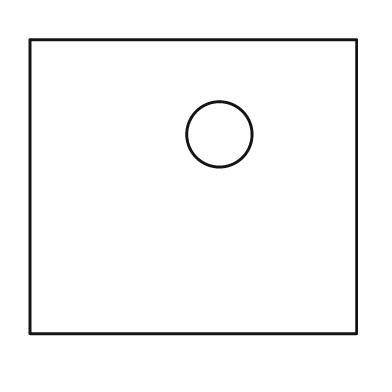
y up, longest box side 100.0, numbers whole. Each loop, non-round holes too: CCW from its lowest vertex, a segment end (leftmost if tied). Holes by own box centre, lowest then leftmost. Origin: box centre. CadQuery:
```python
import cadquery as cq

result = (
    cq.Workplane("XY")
    .moveTo(-50.0, -45.0)
    .lineTo(50.0, -45.0)
    .lineTo(50.0, 45.0)
    .lineTo(-50.0, 45.0)
    .close()
    .moveTo(8.0, 16.0)
    .circle(10.0)
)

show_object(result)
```